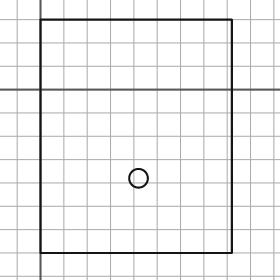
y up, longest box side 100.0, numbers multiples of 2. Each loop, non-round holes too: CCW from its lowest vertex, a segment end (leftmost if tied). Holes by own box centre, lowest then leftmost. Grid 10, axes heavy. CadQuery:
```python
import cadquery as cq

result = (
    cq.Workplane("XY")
    .moveTo(0.0, -70.0)
    .lineTo(82.0, -70.0)
    .lineTo(82.0, 30.0)
    .lineTo(0.0, 30.0)
    .close()
    .moveTo(42.0, -38.0)
    .circle(4.0)
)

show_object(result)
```